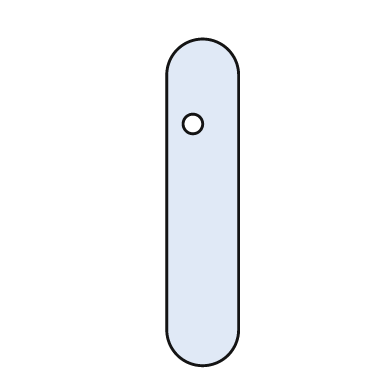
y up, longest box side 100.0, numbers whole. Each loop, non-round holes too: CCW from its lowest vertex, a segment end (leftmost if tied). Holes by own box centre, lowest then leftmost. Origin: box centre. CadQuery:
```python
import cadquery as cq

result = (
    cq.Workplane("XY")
    .moveTo(-11.0, -39.0)
    .threePointArc((0.0, -50.0), (11.0, -39.0))
    .lineTo(11.0, 39.0)
    .threePointArc((0.0, 50.0), (-11.0, 39.0))
    .close()
    .moveTo(-3.0, 24.0)
    .circle(3.0)
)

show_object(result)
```